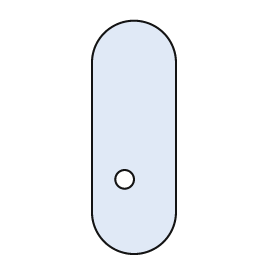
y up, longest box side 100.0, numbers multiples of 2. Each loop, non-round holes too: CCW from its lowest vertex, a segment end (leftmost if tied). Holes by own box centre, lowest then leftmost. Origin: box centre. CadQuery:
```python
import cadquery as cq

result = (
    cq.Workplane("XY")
    .moveTo(-18.0, -32.0)
    .threePointArc((0.0, -50.0), (18.0, -32.0))
    .lineTo(18.0, 32.0)
    .threePointArc((0.0, 50.0), (-18.0, 32.0))
    .close()
    .moveTo(-4.0, -18.0)
    .circle(4.0)
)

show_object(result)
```